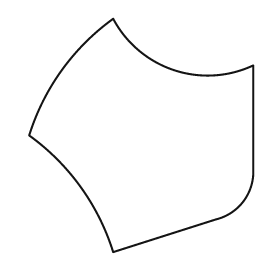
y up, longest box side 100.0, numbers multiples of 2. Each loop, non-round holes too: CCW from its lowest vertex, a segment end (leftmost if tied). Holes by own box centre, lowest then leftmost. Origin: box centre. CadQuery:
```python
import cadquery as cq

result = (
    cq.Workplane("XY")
    .moveTo(-12.0, -50.0)
    .lineTo(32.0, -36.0)
    .threePointArc((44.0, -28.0), (48.0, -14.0))
    .lineTo(48.0, 30.0)
    .threePointArc((14.0, 28.0), (-12.0, 50.0))
    .threePointArc((-34.0, 28.0), (-48.0, 0.0))
    .threePointArc((-26.0, -22.0), (-12.0, -50.0))
    .close()
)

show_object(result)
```